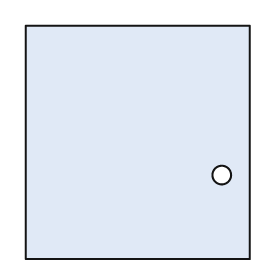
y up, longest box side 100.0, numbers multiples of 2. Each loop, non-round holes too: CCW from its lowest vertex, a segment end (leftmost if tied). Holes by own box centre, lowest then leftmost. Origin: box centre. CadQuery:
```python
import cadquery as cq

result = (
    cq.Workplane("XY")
    .moveTo(-48.0, -50.0)
    .lineTo(48.0, -50.0)
    .lineTo(48.0, 50.0)
    .lineTo(-48.0, 50.0)
    .close()
    .moveTo(36.0, -14.0)
    .circle(4.0)
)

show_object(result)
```